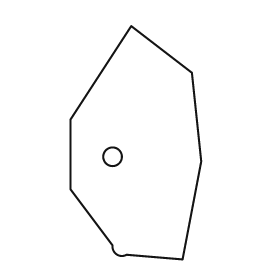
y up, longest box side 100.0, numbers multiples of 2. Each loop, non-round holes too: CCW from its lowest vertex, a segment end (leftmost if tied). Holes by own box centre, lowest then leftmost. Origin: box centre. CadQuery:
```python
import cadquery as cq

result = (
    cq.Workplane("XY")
    .moveTo(20.0, -50.0)
    .lineTo(28.0, -8.0)
    .lineTo(24.0, 30.0)
    .lineTo(-2.0, 50.0)
    .lineTo(-28.0, 10.0)
    .lineTo(-28.0, -20.0)
    .lineTo(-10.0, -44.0)
    .threePointArc((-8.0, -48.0), (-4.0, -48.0))
    .close()
    .moveTo(-10.0, -6.0)
    .circle(4.0)
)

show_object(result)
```